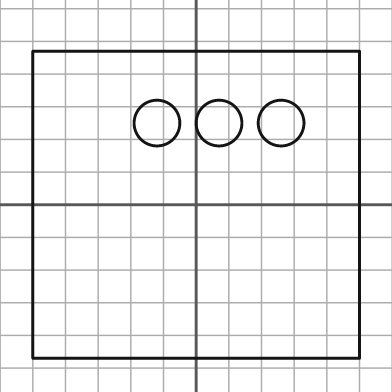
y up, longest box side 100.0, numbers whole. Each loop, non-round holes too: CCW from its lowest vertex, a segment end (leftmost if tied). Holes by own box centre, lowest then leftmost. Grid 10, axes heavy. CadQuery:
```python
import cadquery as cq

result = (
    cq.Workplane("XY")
    .moveTo(-50.0, -47.0)
    .lineTo(50.0, -47.0)
    .lineTo(50.0, 47.0)
    .lineTo(-50.0, 47.0)
    .close()
    .moveTo(-12.0, 25.0)
    .circle(7.0)
    .moveTo(7.0, 25.0)
    .circle(7.0)
    .moveTo(26.0, 25.0)
    .circle(7.0)
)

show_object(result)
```